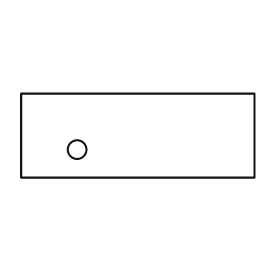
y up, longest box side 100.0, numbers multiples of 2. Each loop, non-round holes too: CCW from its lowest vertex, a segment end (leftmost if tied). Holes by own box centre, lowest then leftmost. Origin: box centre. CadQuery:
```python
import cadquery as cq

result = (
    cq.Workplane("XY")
    .moveTo(-50.0, -18.0)
    .lineTo(50.0, -18.0)
    .lineTo(50.0, 18.0)
    .lineTo(-50.0, 18.0)
    .close()
    .moveTo(-26.0, -6.0)
    .circle(4.0)
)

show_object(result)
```